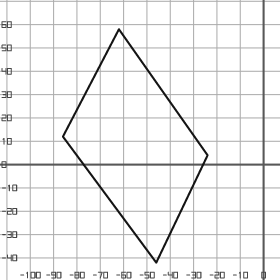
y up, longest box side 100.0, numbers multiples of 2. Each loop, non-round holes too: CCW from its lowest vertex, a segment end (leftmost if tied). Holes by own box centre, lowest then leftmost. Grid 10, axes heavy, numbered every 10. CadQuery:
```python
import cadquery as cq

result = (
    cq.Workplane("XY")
    .moveTo(-46.0, -42.0)
    .lineTo(-24.0, 4.0)
    .lineTo(-62.0, 58.0)
    .lineTo(-86.0, 12.0)
    .close()
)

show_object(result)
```